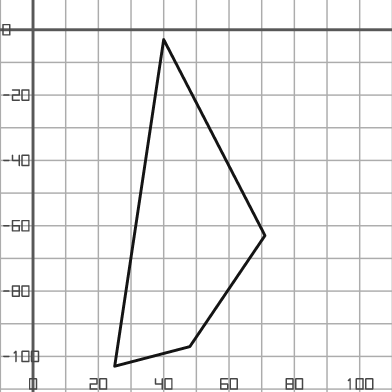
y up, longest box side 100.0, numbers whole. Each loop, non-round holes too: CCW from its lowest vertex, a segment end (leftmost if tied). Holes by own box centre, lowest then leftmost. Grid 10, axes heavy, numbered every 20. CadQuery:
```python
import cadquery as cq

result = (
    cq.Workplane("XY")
    .moveTo(25.0, -103.0)
    .lineTo(48.0, -97.0)
    .lineTo(71.0, -63.0)
    .lineTo(40.0, -3.0)
    .close()
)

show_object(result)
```